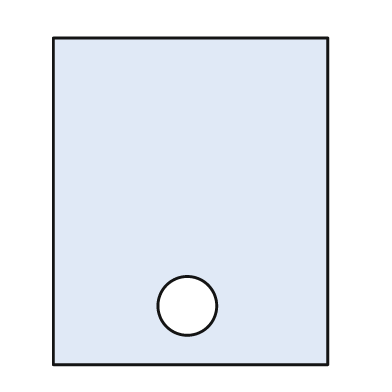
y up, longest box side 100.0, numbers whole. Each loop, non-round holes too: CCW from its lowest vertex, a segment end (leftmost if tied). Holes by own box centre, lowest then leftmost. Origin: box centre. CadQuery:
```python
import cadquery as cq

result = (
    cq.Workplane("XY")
    .moveTo(-42.0, -50.0)
    .lineTo(42.0, -50.0)
    .lineTo(42.0, 50.0)
    .lineTo(-42.0, 50.0)
    .close()
    .moveTo(-1.0, -32.0)
    .circle(9.0)
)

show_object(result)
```